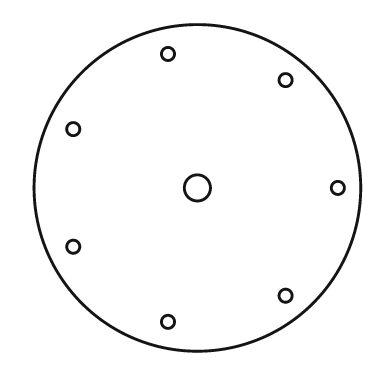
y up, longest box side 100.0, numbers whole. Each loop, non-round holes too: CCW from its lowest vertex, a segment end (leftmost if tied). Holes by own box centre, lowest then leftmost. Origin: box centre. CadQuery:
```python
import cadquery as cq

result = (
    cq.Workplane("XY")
    .moveTo(0.0, 0.0)
    .circle(50.0)
    .moveTo(-9.0, -41.0)
    .circle(2.0)
    .moveTo(27.0, -33.0)
    .circle(2.0)
    .moveTo(-38.0, -18.0)
    .circle(2.0)
    .moveTo(0.0, 0.0)
    .circle(4.0)
    .moveTo(43.0, 0.0)
    .circle(2.0)
    .moveTo(-38.0, 18.0)
    .circle(2.0)
    .moveTo(27.0, 33.0)
    .circle(2.0)
    .moveTo(-9.0, 41.0)
    .circle(2.0)
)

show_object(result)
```